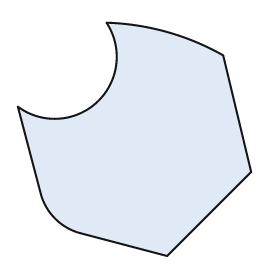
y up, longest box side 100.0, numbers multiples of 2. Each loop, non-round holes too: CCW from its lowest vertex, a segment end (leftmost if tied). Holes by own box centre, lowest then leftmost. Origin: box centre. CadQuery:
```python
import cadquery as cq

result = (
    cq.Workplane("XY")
    .moveTo(14.0, -50.0)
    .lineTo(50.0, -14.0)
    .lineTo(38.0, 36.0)
    .threePointArc((14.0, 46.0), (-12.0, 50.0))
    .threePointArc((-16.0, 16.0), (-50.0, 14.0))
    .lineTo(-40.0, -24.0)
    .threePointArc((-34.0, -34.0), (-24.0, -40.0))
    .close()
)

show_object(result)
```